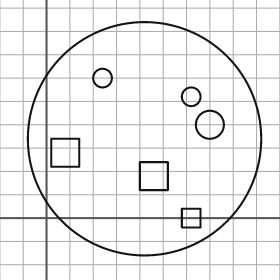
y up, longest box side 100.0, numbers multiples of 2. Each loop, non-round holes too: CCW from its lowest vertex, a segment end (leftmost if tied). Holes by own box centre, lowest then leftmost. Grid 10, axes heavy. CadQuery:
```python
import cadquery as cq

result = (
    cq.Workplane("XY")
    .moveTo(42.0, 34.0)
    .circle(50.0)
    .moveTo(58.0, -4.0)
    .lineTo(66.0, -4.0)
    .lineTo(66.0, 4.0)
    .lineTo(58.0, 4.0)
    .close()
    .moveTo(40.0, 12.0)
    .lineTo(52.0, 12.0)
    .lineTo(52.0, 24.0)
    .lineTo(40.0, 24.0)
    .close()
    .moveTo(2.0, 22.0)
    .lineTo(14.0, 22.0)
    .lineTo(14.0, 34.0)
    .lineTo(2.0, 34.0)
    .close()
    .moveTo(70.0, 40.0)
    .circle(6.0)
    .moveTo(62.0, 52.0)
    .circle(4.0)
    .moveTo(24.0, 60.0)
    .circle(4.0)
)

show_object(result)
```